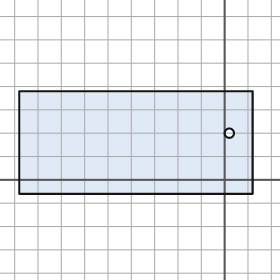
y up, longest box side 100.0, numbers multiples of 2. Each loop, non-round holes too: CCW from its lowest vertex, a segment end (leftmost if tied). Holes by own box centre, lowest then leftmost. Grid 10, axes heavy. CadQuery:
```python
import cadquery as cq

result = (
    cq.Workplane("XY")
    .moveTo(-88.0, -6.0)
    .lineTo(12.0, -6.0)
    .lineTo(12.0, 38.0)
    .lineTo(-88.0, 38.0)
    .close()
    .moveTo(2.0, 20.0)
    .circle(2.0)
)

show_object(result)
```